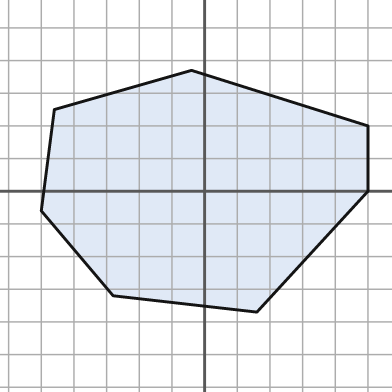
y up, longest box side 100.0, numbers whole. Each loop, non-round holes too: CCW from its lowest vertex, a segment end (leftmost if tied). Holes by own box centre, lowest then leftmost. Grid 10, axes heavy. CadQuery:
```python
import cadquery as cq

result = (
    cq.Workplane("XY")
    .moveTo(16.0, -37.0)
    .lineTo(50.0, 0.0)
    .lineTo(50.0, 20.0)
    .lineTo(-4.0, 37.0)
    .lineTo(-46.0, 25.0)
    .lineTo(-50.0, -6.0)
    .lineTo(-28.0, -32.0)
    .close()
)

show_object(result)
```